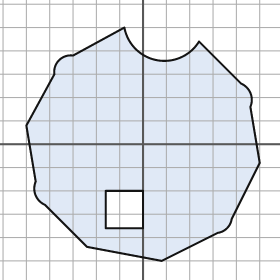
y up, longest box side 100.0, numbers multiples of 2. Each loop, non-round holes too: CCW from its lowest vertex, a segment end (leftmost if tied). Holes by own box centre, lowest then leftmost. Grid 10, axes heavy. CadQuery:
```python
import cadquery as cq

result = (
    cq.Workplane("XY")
    .moveTo(8.0, -50.0)
    .lineTo(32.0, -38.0)
    .threePointArc((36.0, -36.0), (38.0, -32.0))
    .lineTo(50.0, -8.0)
    .lineTo(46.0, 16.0)
    .threePointArc((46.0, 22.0), (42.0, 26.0))
    .lineTo(24.0, 44.0)
    .threePointArc((6.0, 36.0), (-8.0, 50.0))
    .lineTo(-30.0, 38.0)
    .threePointArc((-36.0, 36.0), (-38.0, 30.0))
    .lineTo(-50.0, 8.0)
    .lineTo(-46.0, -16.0)
    .threePointArc((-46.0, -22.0), (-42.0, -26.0))
    .lineTo(-24.0, -44.0)
    .close()
    .moveTo(-16.0, -36.0)
    .lineTo(0.0, -36.0)
    .lineTo(0.0, -20.0)
    .lineTo(-16.0, -20.0)
    .close()
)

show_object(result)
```